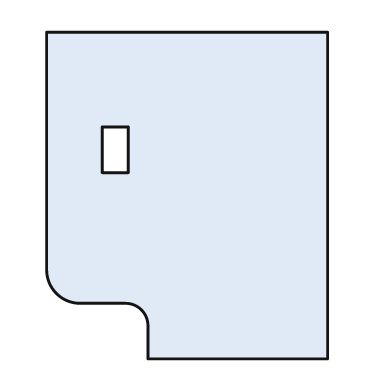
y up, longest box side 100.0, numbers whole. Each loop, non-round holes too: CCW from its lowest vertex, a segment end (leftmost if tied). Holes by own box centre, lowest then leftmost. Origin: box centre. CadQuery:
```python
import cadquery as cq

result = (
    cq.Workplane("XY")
    .moveTo(-12.0, -50.0)
    .lineTo(43.0, -50.0)
    .lineTo(43.0, 50.0)
    .lineTo(-43.0, 50.0)
    .lineTo(-43.0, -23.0)
    .threePointArc((-40.0, -30.0), (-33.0, -33.0))
    .lineTo(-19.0, -33.0)
    .threePointArc((-14.0, -35.0), (-12.0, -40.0))
    .close()
    .moveTo(-26.0, 7.0)
    .lineTo(-18.0, 7.0)
    .lineTo(-18.0, 21.0)
    .lineTo(-26.0, 21.0)
    .close()
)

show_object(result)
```